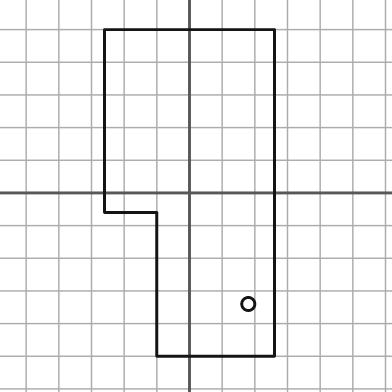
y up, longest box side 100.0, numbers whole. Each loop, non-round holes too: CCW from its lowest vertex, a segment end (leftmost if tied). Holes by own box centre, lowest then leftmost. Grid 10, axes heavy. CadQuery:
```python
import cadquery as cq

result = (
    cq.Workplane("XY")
    .moveTo(-10.0, -50.0)
    .lineTo(26.0, -50.0)
    .lineTo(26.0, 50.0)
    .lineTo(-26.0, 50.0)
    .lineTo(-26.0, -6.0)
    .lineTo(-10.0, -6.0)
    .close()
    .moveTo(18.0, -34.0)
    .circle(2.0)
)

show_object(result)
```